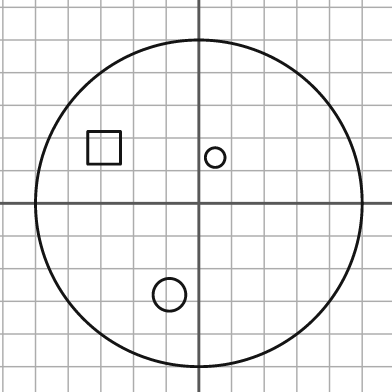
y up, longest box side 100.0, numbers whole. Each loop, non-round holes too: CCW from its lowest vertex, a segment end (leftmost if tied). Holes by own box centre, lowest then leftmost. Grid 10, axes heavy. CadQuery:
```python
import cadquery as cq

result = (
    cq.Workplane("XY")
    .moveTo(0.0, 0.0)
    .circle(50.0)
    .moveTo(-9.0, -28.0)
    .circle(5.0)
    .moveTo(5.0, 14.0)
    .circle(3.0)
    .moveTo(-34.0, 12.0)
    .lineTo(-24.0, 12.0)
    .lineTo(-24.0, 22.0)
    .lineTo(-34.0, 22.0)
    .close()
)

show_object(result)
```